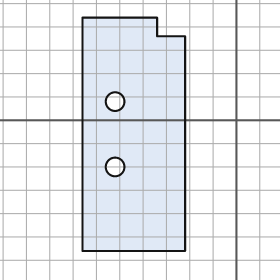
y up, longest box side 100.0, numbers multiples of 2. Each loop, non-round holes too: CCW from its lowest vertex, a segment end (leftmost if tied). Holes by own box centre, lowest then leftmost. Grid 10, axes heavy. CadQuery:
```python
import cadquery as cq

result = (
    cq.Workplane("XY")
    .moveTo(-66.0, -56.0)
    .lineTo(-22.0, -56.0)
    .lineTo(-22.0, 36.0)
    .lineTo(-34.0, 36.0)
    .lineTo(-34.0, 44.0)
    .lineTo(-66.0, 44.0)
    .close()
    .moveTo(-52.0, -20.0)
    .circle(4.0)
    .moveTo(-52.0, 8.0)
    .circle(4.0)
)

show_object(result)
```